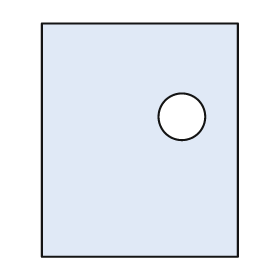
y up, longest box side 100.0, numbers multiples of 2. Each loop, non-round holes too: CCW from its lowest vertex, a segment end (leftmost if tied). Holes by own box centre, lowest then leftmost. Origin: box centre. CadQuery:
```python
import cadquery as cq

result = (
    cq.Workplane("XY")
    .moveTo(-42.0, -50.0)
    .lineTo(42.0, -50.0)
    .lineTo(42.0, 50.0)
    .lineTo(-42.0, 50.0)
    .close()
    .moveTo(18.0, 10.0)
    .circle(10.0)
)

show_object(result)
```